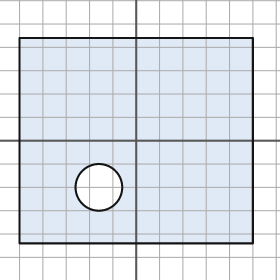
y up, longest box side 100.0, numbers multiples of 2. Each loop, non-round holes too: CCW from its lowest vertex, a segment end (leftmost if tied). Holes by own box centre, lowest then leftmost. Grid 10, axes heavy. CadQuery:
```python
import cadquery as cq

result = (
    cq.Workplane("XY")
    .moveTo(-50.0, -44.0)
    .lineTo(50.0, -44.0)
    .lineTo(50.0, 44.0)
    .lineTo(-50.0, 44.0)
    .close()
    .moveTo(-16.0, -20.0)
    .circle(10.0)
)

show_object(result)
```